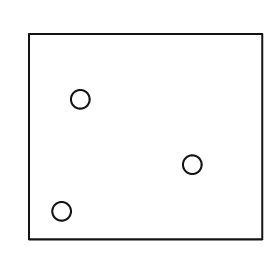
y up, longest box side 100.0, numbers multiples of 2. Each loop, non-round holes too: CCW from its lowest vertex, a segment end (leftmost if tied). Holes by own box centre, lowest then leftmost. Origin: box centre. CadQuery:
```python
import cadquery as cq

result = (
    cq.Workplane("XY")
    .moveTo(-50.0, -44.0)
    .lineTo(50.0, -44.0)
    .lineTo(50.0, 44.0)
    .lineTo(-50.0, 44.0)
    .close()
    .moveTo(-36.0, -32.0)
    .circle(4.0)
    .moveTo(20.0, -12.0)
    .circle(4.0)
    .moveTo(-28.0, 16.0)
    .circle(4.0)
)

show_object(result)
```